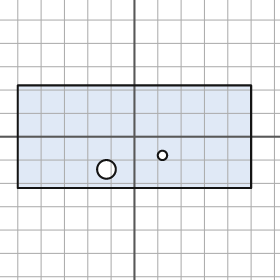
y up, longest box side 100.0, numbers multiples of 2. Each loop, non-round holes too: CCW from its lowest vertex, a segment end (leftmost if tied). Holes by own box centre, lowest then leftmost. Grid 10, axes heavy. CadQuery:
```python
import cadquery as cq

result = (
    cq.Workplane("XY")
    .moveTo(-50.0, -22.0)
    .lineTo(50.0, -22.0)
    .lineTo(50.0, 22.0)
    .lineTo(-50.0, 22.0)
    .close()
    .moveTo(-12.0, -14.0)
    .circle(4.0)
    .moveTo(12.0, -8.0)
    .circle(2.0)
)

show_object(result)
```